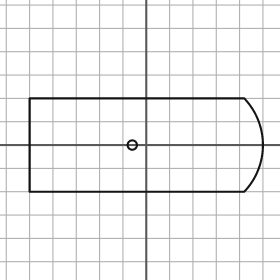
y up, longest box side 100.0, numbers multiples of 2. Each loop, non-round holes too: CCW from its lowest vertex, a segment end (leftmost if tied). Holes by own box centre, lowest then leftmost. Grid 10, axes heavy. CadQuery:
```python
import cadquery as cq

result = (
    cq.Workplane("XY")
    .moveTo(-50.0, -20.0)
    .lineTo(42.0, -20.0)
    .threePointArc((50.0, 0.0), (42.0, 20.0))
    .lineTo(-50.0, 20.0)
    .close()
    .moveTo(-6.0, 0.0)
    .circle(2.0)
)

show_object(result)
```